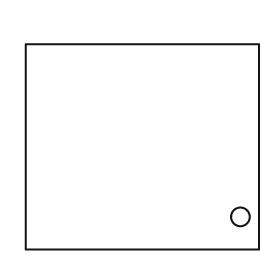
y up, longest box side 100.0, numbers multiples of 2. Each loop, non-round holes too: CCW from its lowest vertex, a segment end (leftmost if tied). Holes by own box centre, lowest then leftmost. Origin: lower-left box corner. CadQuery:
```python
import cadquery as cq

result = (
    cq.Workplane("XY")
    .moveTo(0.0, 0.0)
    .lineTo(100.0, 0.0)
    .lineTo(100.0, 88.0)
    .lineTo(0.0, 88.0)
    .close()
    .moveTo(92.0, 14.0)
    .circle(4.0)
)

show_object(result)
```